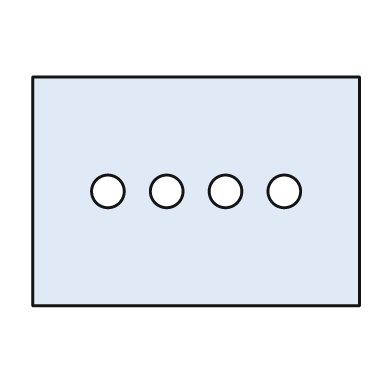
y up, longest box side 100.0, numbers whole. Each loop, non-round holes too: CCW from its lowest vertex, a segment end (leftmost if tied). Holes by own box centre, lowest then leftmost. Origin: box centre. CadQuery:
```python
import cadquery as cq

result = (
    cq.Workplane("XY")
    .moveTo(-50.0, -35.0)
    .lineTo(50.0, -35.0)
    .lineTo(50.0, 35.0)
    .lineTo(-50.0, 35.0)
    .close()
    .moveTo(-27.0, 0.0)
    .circle(5.0)
    .moveTo(-9.0, 0.0)
    .circle(5.0)
    .moveTo(9.0, 0.0)
    .circle(5.0)
    .moveTo(27.0, 0.0)
    .circle(5.0)
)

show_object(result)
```